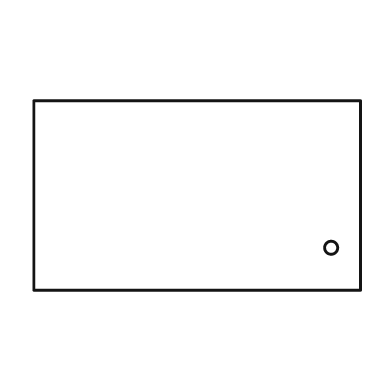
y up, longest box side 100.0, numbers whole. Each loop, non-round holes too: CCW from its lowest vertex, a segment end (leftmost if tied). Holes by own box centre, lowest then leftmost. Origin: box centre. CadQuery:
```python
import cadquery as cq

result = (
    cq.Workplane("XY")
    .moveTo(-50.0, -29.0)
    .lineTo(50.0, -29.0)
    .lineTo(50.0, 29.0)
    .lineTo(-50.0, 29.0)
    .close()
    .moveTo(41.0, -16.0)
    .circle(2.0)
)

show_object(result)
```